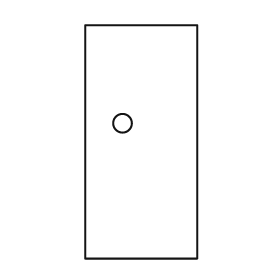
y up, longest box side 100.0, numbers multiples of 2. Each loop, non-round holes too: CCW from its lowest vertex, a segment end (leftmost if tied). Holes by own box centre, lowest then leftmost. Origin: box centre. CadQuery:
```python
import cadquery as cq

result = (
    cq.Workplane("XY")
    .moveTo(-24.0, -50.0)
    .lineTo(24.0, -50.0)
    .lineTo(24.0, 50.0)
    .lineTo(-24.0, 50.0)
    .close()
    .moveTo(-8.0, 8.0)
    .circle(4.0)
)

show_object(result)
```